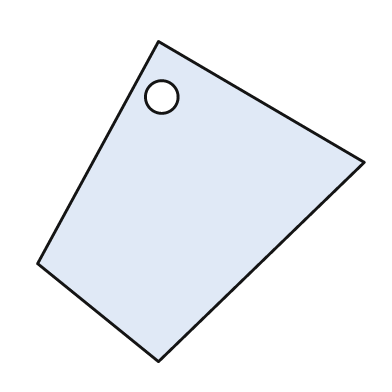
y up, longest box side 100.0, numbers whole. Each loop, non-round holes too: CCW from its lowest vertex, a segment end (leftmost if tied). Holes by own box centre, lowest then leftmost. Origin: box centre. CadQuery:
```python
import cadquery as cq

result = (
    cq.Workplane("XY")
    .moveTo(-13.0, -49.0)
    .lineTo(50.0, 12.0)
    .lineTo(-13.0, 49.0)
    .lineTo(-50.0, -19.0)
    .close()
    .moveTo(-12.0, 32.0)
    .circle(5.0)
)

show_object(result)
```